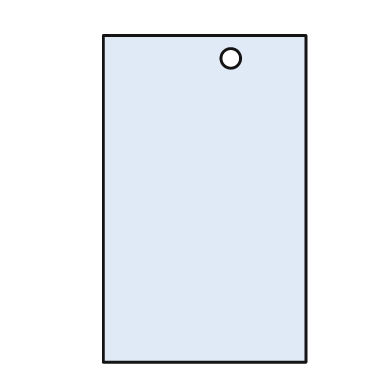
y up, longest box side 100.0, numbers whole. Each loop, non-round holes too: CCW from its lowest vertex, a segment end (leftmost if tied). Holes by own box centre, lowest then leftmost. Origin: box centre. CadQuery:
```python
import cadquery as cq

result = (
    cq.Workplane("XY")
    .moveTo(-31.0, -50.0)
    .lineTo(31.0, -50.0)
    .lineTo(31.0, 50.0)
    .lineTo(-31.0, 50.0)
    .close()
    .moveTo(8.0, 43.0)
    .circle(3.0)
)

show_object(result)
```